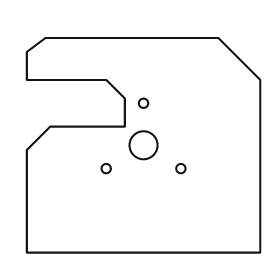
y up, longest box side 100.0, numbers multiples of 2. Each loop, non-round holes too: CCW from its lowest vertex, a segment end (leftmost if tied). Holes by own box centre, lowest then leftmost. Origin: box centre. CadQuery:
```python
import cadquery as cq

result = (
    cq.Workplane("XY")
    .moveTo(-50.0, -46.0)
    .lineTo(50.0, -46.0)
    .lineTo(50.0, 28.0)
    .lineTo(32.0, 46.0)
    .lineTo(-42.0, 46.0)
    .lineTo(-50.0, 40.0)
    .lineTo(-50.0, 28.0)
    .lineTo(-16.0, 28.0)
    .lineTo(-8.0, 20.0)
    .lineTo(-8.0, 8.0)
    .lineTo(-40.0, 8.0)
    .lineTo(-50.0, -2.0)
    .close()
    .moveTo(-16.0, -10.0)
    .circle(2.0)
    .moveTo(16.0, -10.0)
    .circle(2.0)
    .moveTo(0.0, 0.0)
    .circle(6.0)
    .moveTo(0.0, 18.0)
    .circle(2.0)
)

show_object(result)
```